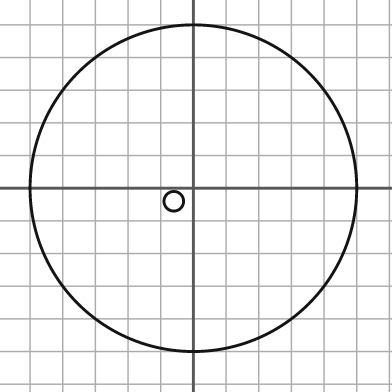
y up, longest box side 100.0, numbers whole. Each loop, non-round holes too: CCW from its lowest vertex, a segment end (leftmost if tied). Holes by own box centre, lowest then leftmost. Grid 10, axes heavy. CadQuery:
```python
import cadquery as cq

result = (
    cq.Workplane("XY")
    .moveTo(0.0, 0.0)
    .circle(50.0)
    .moveTo(-6.0, -4.0)
    .circle(3.0)
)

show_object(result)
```